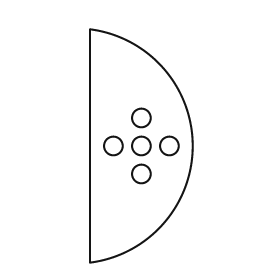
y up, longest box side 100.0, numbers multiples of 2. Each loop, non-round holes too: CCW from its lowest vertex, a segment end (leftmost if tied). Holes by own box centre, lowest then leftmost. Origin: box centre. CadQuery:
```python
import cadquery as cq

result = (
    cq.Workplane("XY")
    .moveTo(-22.0, -50.0)
    .threePointArc((22.0, 0.0), (-22.0, 50.0))
    .close()
    .moveTo(0.0, -12.0)
    .circle(4.0)
    .moveTo(-12.0, 0.0)
    .circle(4.0)
    .moveTo(0.0, 0.0)
    .circle(4.0)
    .moveTo(12.0, 0.0)
    .circle(4.0)
    .moveTo(0.0, 12.0)
    .circle(4.0)
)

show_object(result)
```